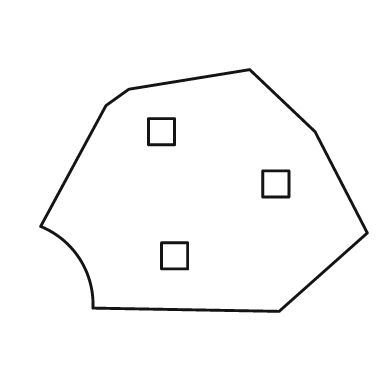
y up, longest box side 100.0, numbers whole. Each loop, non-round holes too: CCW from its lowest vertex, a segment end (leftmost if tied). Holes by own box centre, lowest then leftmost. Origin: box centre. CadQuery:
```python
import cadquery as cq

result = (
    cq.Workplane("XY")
    .moveTo(23.0, -37.0)
    .lineTo(50.0, -13.0)
    .lineTo(34.0, 18.0)
    .lineTo(14.0, 37.0)
    .lineTo(-23.0, 31.0)
    .lineTo(-30.0, 26.0)
    .lineTo(-50.0, -11.0)
    .threePointArc((-38.0, -21.0), (-34.0, -36.0))
    .close()
    .moveTo(-13.0, -24.0)
    .lineTo(-5.0, -24.0)
    .lineTo(-5.0, -16.0)
    .lineTo(-13.0, -16.0)
    .close()
    .moveTo(18.0, -2.0)
    .lineTo(26.0, -2.0)
    .lineTo(26.0, 6.0)
    .lineTo(18.0, 6.0)
    .close()
    .moveTo(-17.0, 14.0)
    .lineTo(-9.0, 14.0)
    .lineTo(-9.0, 22.0)
    .lineTo(-17.0, 22.0)
    .close()
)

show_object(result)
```